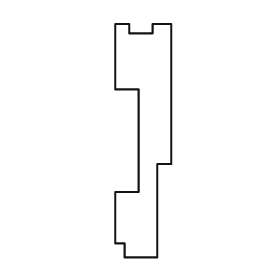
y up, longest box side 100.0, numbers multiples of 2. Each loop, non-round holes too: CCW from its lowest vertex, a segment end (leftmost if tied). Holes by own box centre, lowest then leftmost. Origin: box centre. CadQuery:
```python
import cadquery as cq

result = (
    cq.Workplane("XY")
    .moveTo(-8.0, -50.0)
    .lineTo(6.0, -50.0)
    .lineTo(6.0, -10.0)
    .lineTo(12.0, -10.0)
    .lineTo(12.0, 50.0)
    .lineTo(4.0, 50.0)
    .lineTo(4.0, 46.0)
    .lineTo(-6.0, 46.0)
    .lineTo(-6.0, 50.0)
    .lineTo(-12.0, 50.0)
    .lineTo(-12.0, 22.0)
    .lineTo(-2.0, 22.0)
    .lineTo(-2.0, -22.0)
    .lineTo(-12.0, -22.0)
    .lineTo(-12.0, -44.0)
    .lineTo(-8.0, -44.0)
    .close()
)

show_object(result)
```